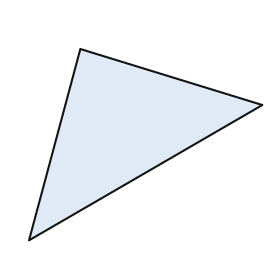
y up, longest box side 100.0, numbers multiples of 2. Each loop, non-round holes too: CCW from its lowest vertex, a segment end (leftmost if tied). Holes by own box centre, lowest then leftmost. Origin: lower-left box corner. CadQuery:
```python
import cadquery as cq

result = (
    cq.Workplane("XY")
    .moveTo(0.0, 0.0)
    .lineTo(100.0, 58.0)
    .lineTo(22.0, 82.0)
    .close()
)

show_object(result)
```